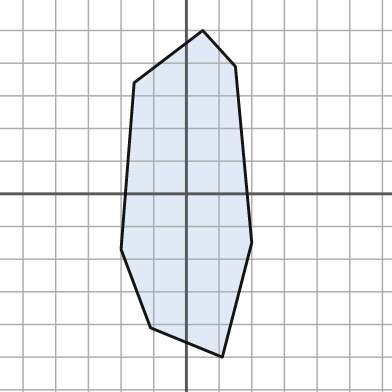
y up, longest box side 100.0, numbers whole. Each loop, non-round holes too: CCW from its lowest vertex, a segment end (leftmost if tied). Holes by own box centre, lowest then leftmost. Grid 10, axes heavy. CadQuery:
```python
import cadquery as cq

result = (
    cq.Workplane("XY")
    .moveTo(11.0, -50.0)
    .lineTo(20.0, -15.0)
    .lineTo(15.0, 39.0)
    .lineTo(5.0, 50.0)
    .lineTo(-16.0, 34.0)
    .lineTo(-20.0, -17.0)
    .lineTo(-11.0, -41.0)
    .close()
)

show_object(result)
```